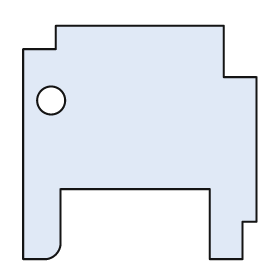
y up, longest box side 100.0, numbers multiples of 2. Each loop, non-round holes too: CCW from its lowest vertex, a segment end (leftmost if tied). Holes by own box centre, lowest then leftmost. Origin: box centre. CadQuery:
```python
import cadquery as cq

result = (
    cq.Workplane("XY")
    .moveTo(-50.0, -50.0)
    .lineTo(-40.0, -50.0)
    .threePointArc((-36.0, -48.0), (-34.0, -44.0))
    .lineTo(-34.0, -20.0)
    .lineTo(30.0, -20.0)
    .lineTo(30.0, -50.0)
    .lineTo(44.0, -50.0)
    .lineTo(44.0, -34.0)
    .lineTo(50.0, -34.0)
    .lineTo(50.0, 28.0)
    .lineTo(36.0, 28.0)
    .lineTo(36.0, 50.0)
    .lineTo(-36.0, 50.0)
    .lineTo(-36.0, 40.0)
    .lineTo(-50.0, 40.0)
    .close()
    .moveTo(-38.0, 18.0)
    .circle(6.0)
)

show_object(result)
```